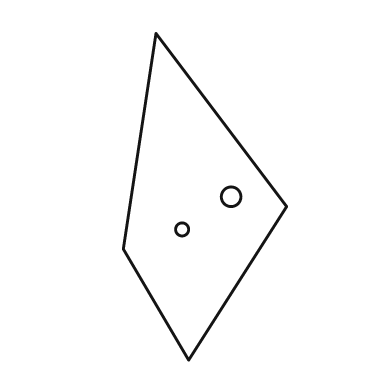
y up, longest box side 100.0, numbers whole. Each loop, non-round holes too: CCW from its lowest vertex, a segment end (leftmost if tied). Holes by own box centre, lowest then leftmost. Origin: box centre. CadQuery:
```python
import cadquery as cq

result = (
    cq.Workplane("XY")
    .moveTo(-5.0, -50.0)
    .lineTo(25.0, -3.0)
    .lineTo(-15.0, 50.0)
    .lineTo(-25.0, -16.0)
    .close()
    .moveTo(-7.0, -10.0)
    .circle(2.0)
    .moveTo(8.0, 0.0)
    .circle(3.0)
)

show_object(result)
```